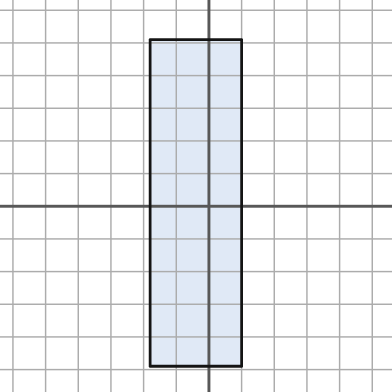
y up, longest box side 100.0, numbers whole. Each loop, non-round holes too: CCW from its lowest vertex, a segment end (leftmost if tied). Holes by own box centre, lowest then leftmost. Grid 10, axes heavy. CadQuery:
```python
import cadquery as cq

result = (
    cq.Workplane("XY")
    .moveTo(-18.0, -49.0)
    .lineTo(10.0, -49.0)
    .lineTo(10.0, 51.0)
    .lineTo(-18.0, 51.0)
    .close()
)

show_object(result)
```